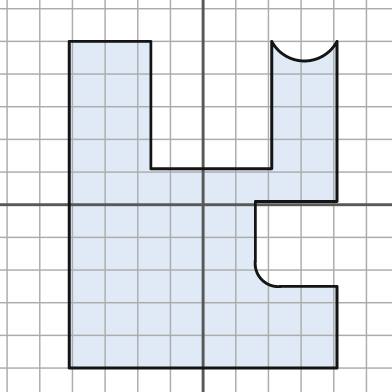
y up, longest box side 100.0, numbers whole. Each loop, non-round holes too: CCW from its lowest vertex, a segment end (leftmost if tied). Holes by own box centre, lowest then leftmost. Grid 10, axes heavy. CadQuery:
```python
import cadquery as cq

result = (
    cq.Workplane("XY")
    .moveTo(-41.0, -50.0)
    .lineTo(41.0, -50.0)
    .lineTo(41.0, -25.0)
    .lineTo(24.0, -25.0)
    .threePointArc((18.0, -23.0), (16.0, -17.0))
    .lineTo(16.0, 1.0)
    .lineTo(41.0, 1.0)
    .lineTo(41.0, 50.0)
    .threePointArc((31.0, 44.0), (21.0, 50.0))
    .lineTo(21.0, 11.0)
    .lineTo(-16.0, 11.0)
    .lineTo(-16.0, 50.0)
    .lineTo(-41.0, 50.0)
    .close()
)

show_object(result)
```